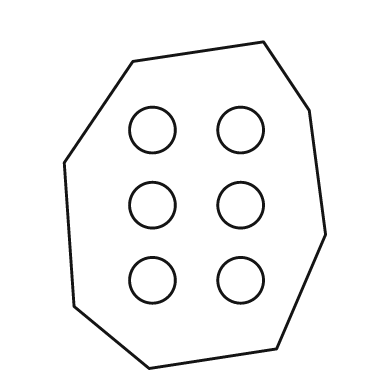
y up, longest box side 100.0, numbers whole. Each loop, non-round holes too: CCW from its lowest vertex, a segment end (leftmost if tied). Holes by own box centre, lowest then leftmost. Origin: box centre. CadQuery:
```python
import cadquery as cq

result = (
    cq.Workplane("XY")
    .moveTo(-14.0, -50.0)
    .lineTo(25.0, -44.0)
    .lineTo(40.0, -9.0)
    .lineTo(35.0, 29.0)
    .lineTo(21.0, 50.0)
    .lineTo(-19.0, 44.0)
    .lineTo(-40.0, 13.0)
    .lineTo(-37.0, -31.0)
    .close()
    .moveTo(-13.0, -23.0)
    .circle(7.0)
    .moveTo(14.0, -23.0)
    .circle(7.0)
    .moveTo(-13.0, 0.0)
    .circle(7.0)
    .moveTo(14.0, 0.0)
    .circle(7.0)
    .moveTo(-13.0, 23.0)
    .circle(7.0)
    .moveTo(14.0, 23.0)
    .circle(7.0)
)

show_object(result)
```